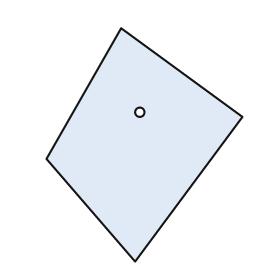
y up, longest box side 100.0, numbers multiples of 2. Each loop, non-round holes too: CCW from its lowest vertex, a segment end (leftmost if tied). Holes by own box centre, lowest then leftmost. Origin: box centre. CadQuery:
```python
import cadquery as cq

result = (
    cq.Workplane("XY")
    .moveTo(-4.0, -50.0)
    .lineTo(42.0, 12.0)
    .lineTo(-10.0, 50.0)
    .lineTo(-42.0, -6.0)
    .close()
    .moveTo(-2.0, 14.0)
    .circle(2.0)
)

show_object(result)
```